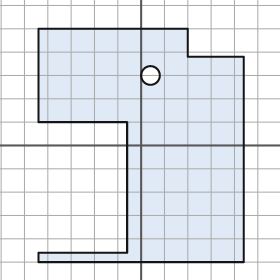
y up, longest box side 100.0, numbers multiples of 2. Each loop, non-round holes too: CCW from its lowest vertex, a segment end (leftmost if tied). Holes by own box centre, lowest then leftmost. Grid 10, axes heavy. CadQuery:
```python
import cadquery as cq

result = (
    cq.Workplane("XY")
    .moveTo(-44.0, -50.0)
    .lineTo(44.0, -50.0)
    .lineTo(44.0, 38.0)
    .lineTo(20.0, 38.0)
    .lineTo(20.0, 50.0)
    .lineTo(-44.0, 50.0)
    .lineTo(-44.0, 10.0)
    .lineTo(-6.0, 10.0)
    .lineTo(-6.0, -46.0)
    .lineTo(-44.0, -46.0)
    .close()
    .moveTo(4.0, 30.0)
    .circle(4.0)
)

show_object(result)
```